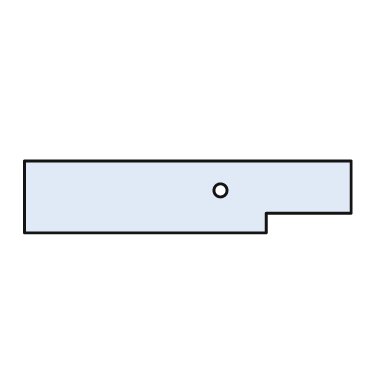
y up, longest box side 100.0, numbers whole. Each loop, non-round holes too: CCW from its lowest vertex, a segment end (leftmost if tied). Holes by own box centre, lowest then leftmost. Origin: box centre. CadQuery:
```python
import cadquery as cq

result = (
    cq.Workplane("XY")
    .moveTo(-50.0, -11.0)
    .lineTo(24.0, -11.0)
    .lineTo(24.0, -5.0)
    .lineTo(50.0, -5.0)
    .lineTo(50.0, 11.0)
    .lineTo(-50.0, 11.0)
    .close()
    .moveTo(10.0, 2.0)
    .circle(2.0)
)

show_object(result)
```